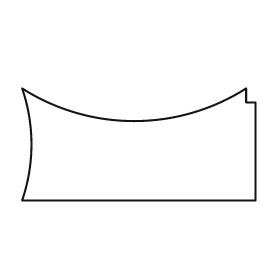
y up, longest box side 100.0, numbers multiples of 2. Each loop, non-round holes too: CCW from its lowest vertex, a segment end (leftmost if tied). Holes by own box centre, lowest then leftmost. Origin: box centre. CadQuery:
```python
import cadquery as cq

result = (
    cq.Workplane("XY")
    .moveTo(-50.0, -24.0)
    .lineTo(50.0, -24.0)
    .lineTo(50.0, 18.0)
    .lineTo(46.0, 18.0)
    .lineTo(46.0, 24.0)
    .threePointArc((-2.0, 10.0), (-50.0, 24.0))
    .threePointArc((-46.0, 0.0), (-50.0, -24.0))
    .close()
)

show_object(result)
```